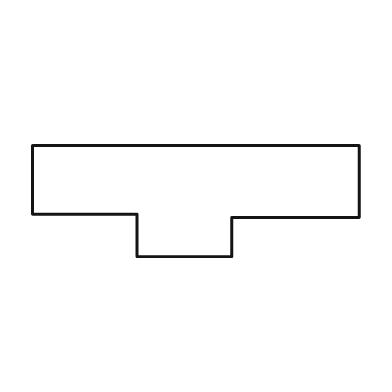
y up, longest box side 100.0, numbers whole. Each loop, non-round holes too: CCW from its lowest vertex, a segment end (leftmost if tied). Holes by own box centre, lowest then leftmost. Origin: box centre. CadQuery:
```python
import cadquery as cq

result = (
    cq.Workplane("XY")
    .moveTo(-18.0, -17.0)
    .lineTo(11.0, -17.0)
    .lineTo(11.0, -5.0)
    .lineTo(50.0, -5.0)
    .lineTo(50.0, 17.0)
    .lineTo(-50.0, 17.0)
    .lineTo(-50.0, -4.0)
    .lineTo(-18.0, -4.0)
    .close()
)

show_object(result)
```